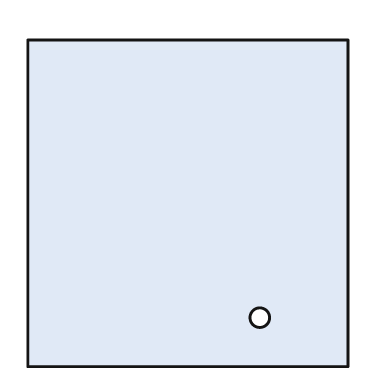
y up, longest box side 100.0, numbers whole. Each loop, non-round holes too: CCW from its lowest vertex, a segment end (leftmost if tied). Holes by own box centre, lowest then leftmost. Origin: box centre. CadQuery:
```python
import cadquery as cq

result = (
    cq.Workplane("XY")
    .moveTo(-49.0, -50.0)
    .lineTo(49.0, -50.0)
    .lineTo(49.0, 50.0)
    .lineTo(-49.0, 50.0)
    .close()
    .moveTo(22.0, -35.0)
    .circle(3.0)
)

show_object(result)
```